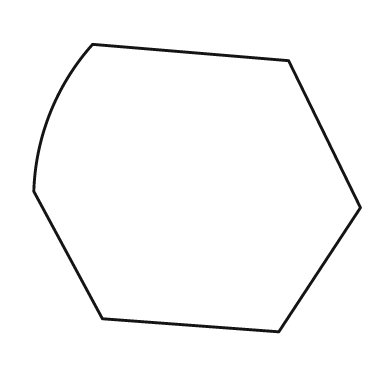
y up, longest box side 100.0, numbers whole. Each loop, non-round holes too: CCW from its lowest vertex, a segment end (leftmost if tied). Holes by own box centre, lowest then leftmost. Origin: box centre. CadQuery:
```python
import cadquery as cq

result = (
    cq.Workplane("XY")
    .moveTo(25.0, -44.0)
    .lineTo(50.0, -6.0)
    .lineTo(28.0, 39.0)
    .lineTo(-32.0, 44.0)
    .threePointArc((-45.0, 23.0), (-50.0, -1.0))
    .lineTo(-29.0, -40.0)
    .close()
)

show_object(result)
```